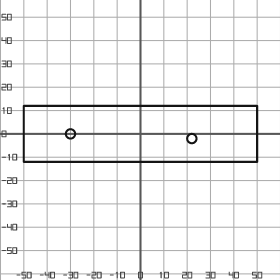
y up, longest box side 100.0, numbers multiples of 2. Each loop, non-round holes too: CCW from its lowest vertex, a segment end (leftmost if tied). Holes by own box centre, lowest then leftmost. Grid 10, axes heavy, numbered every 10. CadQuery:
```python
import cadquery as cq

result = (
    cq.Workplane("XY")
    .moveTo(-50.0, -12.0)
    .lineTo(50.0, -12.0)
    .lineTo(50.0, 12.0)
    .lineTo(-50.0, 12.0)
    .close()
    .moveTo(22.0, -2.0)
    .circle(2.0)
    .moveTo(-30.0, 0.0)
    .circle(2.0)
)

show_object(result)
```